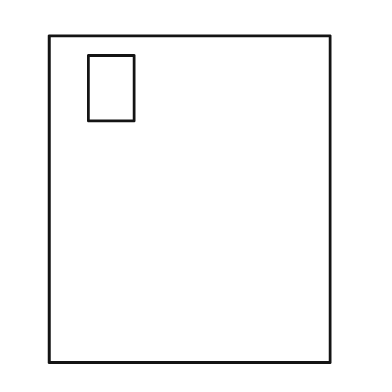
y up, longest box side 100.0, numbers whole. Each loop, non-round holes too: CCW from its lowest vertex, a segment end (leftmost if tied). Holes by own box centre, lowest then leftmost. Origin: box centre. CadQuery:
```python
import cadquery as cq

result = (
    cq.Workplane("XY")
    .moveTo(-43.0, -50.0)
    .lineTo(43.0, -50.0)
    .lineTo(43.0, 50.0)
    .lineTo(-43.0, 50.0)
    .close()
    .moveTo(-31.0, 24.0)
    .lineTo(-17.0, 24.0)
    .lineTo(-17.0, 44.0)
    .lineTo(-31.0, 44.0)
    .close()
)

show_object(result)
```